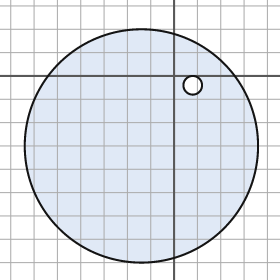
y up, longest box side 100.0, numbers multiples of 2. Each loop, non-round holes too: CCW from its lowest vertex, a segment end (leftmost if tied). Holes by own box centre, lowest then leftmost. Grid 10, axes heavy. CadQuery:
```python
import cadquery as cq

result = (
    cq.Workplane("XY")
    .moveTo(-14.0, -30.0)
    .circle(50.0)
    .moveTo(8.0, -4.0)
    .circle(4.0)
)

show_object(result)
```